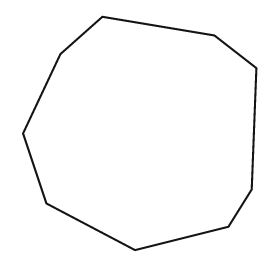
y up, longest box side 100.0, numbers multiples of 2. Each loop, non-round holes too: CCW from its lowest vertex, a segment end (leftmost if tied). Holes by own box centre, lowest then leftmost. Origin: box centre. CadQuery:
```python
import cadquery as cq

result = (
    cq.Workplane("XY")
    .moveTo(-2.0, -50.0)
    .lineTo(38.0, -40.0)
    .lineTo(48.0, -24.0)
    .lineTo(50.0, 28.0)
    .lineTo(32.0, 42.0)
    .lineTo(-16.0, 50.0)
    .lineTo(-34.0, 34.0)
    .lineTo(-50.0, 0.0)
    .lineTo(-40.0, -30.0)
    .close()
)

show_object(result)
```